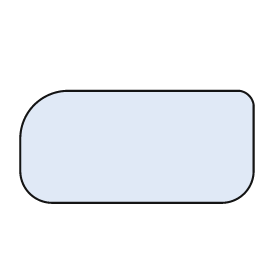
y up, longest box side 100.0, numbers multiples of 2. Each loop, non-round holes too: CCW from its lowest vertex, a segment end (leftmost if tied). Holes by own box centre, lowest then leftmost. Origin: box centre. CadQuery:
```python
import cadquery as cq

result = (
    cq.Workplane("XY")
    .moveTo(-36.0, -24.0)
    .lineTo(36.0, -24.0)
    .threePointArc((46.0, -20.0), (50.0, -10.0))
    .lineTo(50.0, 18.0)
    .threePointArc((48.0, 22.0), (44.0, 24.0))
    .lineTo(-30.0, 24.0)
    .threePointArc((-44.0, 18.0), (-50.0, 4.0))
    .lineTo(-50.0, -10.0)
    .threePointArc((-46.0, -20.0), (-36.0, -24.0))
    .close()
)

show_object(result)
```